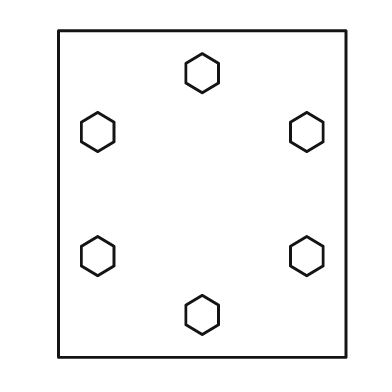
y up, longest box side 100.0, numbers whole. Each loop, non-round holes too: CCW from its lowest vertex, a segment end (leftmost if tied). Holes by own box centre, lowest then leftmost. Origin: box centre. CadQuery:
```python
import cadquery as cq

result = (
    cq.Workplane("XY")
    .moveTo(-44.0, -50.0)
    .lineTo(44.0, -50.0)
    .lineTo(44.0, 50.0)
    .lineTo(-44.0, 50.0)
    .close()
    .moveTo(0.0, -43.0)
    .lineTo(5.0, -40.0)
    .lineTo(5.0, -34.0)
    .lineTo(0.0, -31.0)
    .lineTo(-5.0, -34.0)
    .lineTo(-5.0, -40.0)
    .close()
    .moveTo(-32.0, -25.0)
    .lineTo(-27.0, -22.0)
    .lineTo(-27.0, -16.0)
    .lineTo(-32.0, -13.0)
    .lineTo(-37.0, -16.0)
    .lineTo(-37.0, -22.0)
    .close()
    .moveTo(32.0, -25.0)
    .lineTo(37.0, -22.0)
    .lineTo(37.0, -16.0)
    .lineTo(32.0, -13.0)
    .lineTo(27.0, -16.0)
    .lineTo(27.0, -22.0)
    .close()
    .moveTo(-32.0, 13.0)
    .lineTo(-27.0, 16.0)
    .lineTo(-27.0, 22.0)
    .lineTo(-32.0, 25.0)
    .lineTo(-37.0, 22.0)
    .lineTo(-37.0, 16.0)
    .close()
    .moveTo(32.0, 13.0)
    .lineTo(37.0, 16.0)
    .lineTo(37.0, 22.0)
    .lineTo(32.0, 25.0)
    .lineTo(27.0, 22.0)
    .lineTo(27.0, 16.0)
    .close()
    .moveTo(0.0, 31.0)
    .lineTo(5.0, 34.0)
    .lineTo(5.0, 40.0)
    .lineTo(0.0, 43.0)
    .lineTo(-5.0, 40.0)
    .lineTo(-5.0, 34.0)
    .close()
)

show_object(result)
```